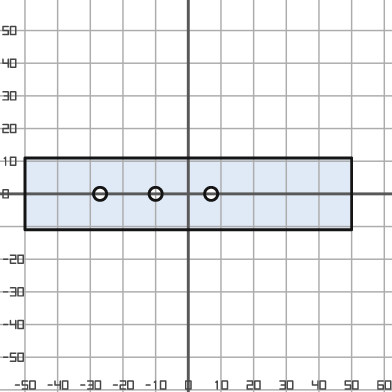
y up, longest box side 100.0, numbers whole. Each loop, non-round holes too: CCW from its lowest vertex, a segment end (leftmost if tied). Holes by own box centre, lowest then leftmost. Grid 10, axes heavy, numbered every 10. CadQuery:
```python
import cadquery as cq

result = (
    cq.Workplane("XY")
    .moveTo(-50.0, -11.0)
    .lineTo(50.0, -11.0)
    .lineTo(50.0, 11.0)
    .lineTo(-50.0, 11.0)
    .close()
    .moveTo(-27.0, 0.0)
    .circle(2.0)
    .moveTo(-10.0, 0.0)
    .circle(2.0)
    .moveTo(7.0, 0.0)
    .circle(2.0)
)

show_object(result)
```